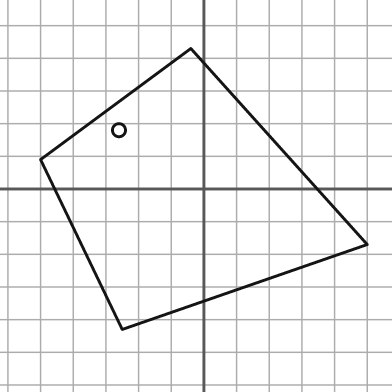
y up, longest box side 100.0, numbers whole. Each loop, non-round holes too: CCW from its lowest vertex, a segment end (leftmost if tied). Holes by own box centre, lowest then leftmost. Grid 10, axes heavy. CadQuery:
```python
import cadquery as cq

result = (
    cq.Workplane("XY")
    .moveTo(-25.0, -43.0)
    .lineTo(50.0, -17.0)
    .lineTo(-4.0, 43.0)
    .lineTo(-50.0, 9.0)
    .close()
    .moveTo(-26.0, 18.0)
    .circle(2.0)
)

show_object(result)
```